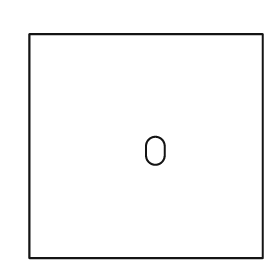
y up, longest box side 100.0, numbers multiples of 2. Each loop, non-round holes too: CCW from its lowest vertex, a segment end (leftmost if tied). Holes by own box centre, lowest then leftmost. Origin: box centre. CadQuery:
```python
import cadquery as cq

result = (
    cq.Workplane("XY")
    .moveTo(-50.0, -48.0)
    .lineTo(50.0, -48.0)
    .lineTo(50.0, 48.0)
    .lineTo(-50.0, 48.0)
    .close()
    .moveTo(0.0, -4.0)
    .threePointArc((4.0, -8.0), (8.0, -4.0))
    .lineTo(8.0, 0.0)
    .threePointArc((4.0, 4.0), (0.0, 0.0))
    .close()
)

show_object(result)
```